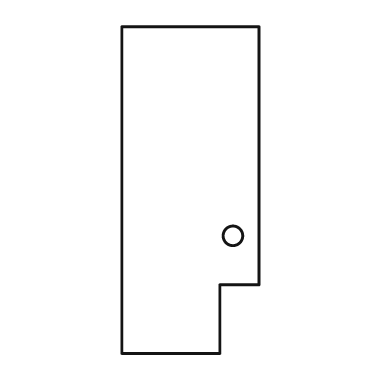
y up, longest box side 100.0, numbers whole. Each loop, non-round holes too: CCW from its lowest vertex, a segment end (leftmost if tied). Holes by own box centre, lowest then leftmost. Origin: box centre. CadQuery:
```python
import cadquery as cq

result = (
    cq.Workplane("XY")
    .moveTo(-21.0, -50.0)
    .lineTo(9.0, -50.0)
    .lineTo(9.0, -29.0)
    .lineTo(21.0, -29.0)
    .lineTo(21.0, 50.0)
    .lineTo(-21.0, 50.0)
    .close()
    .moveTo(13.0, -14.0)
    .circle(3.0)
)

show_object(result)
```